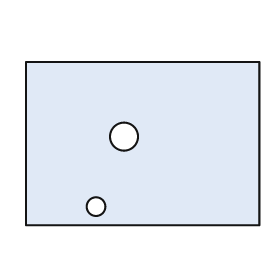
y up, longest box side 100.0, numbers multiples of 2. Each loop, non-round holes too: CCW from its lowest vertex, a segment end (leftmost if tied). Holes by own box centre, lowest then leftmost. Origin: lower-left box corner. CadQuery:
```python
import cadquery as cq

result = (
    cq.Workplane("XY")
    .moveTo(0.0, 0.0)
    .lineTo(100.0, 0.0)
    .lineTo(100.0, 70.0)
    .lineTo(0.0, 70.0)
    .close()
    .moveTo(30.0, 8.0)
    .circle(4.0)
    .moveTo(42.0, 38.0)
    .circle(6.0)
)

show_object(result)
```